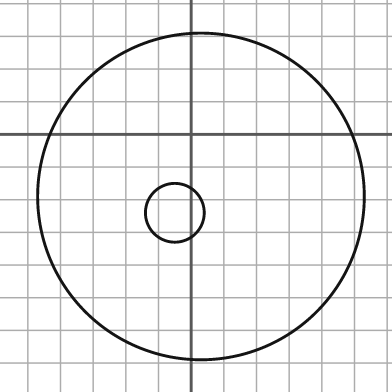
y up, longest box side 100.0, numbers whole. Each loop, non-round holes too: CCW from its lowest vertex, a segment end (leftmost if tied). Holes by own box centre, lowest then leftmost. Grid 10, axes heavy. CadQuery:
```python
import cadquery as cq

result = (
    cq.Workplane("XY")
    .moveTo(3.0, -19.0)
    .circle(50.0)
    .moveTo(-5.0, -24.0)
    .circle(9.0)
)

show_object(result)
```